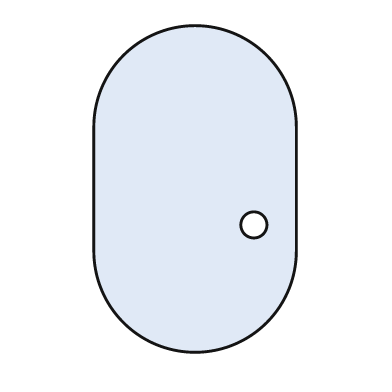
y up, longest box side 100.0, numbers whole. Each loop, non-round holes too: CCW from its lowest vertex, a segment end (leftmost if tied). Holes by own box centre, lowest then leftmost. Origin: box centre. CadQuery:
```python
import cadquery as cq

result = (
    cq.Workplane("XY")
    .moveTo(-31.0, -19.0)
    .threePointArc((0.0, -50.0), (31.0, -19.0))
    .lineTo(31.0, 19.0)
    .threePointArc((0.0, 50.0), (-31.0, 19.0))
    .close()
    .moveTo(18.0, -11.0)
    .circle(4.0)
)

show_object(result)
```